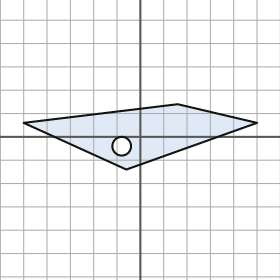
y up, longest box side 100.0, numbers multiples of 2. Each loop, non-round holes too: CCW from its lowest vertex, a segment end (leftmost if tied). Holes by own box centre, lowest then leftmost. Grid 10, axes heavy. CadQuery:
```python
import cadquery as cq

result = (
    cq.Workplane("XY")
    .moveTo(-6.0, -14.0)
    .lineTo(50.0, 6.0)
    .lineTo(16.0, 14.0)
    .lineTo(-50.0, 6.0)
    .close()
    .moveTo(-8.0, -4.0)
    .circle(4.0)
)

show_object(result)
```